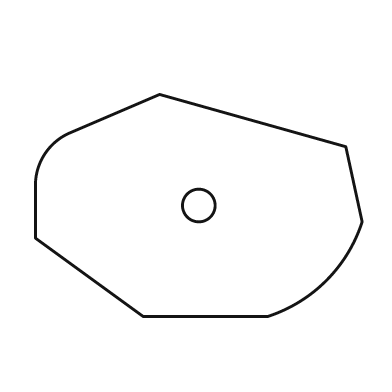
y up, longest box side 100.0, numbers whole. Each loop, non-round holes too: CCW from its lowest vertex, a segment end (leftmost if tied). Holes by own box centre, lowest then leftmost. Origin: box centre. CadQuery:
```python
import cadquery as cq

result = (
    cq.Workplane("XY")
    .moveTo(-17.0, -34.0)
    .lineTo(21.0, -34.0)
    .threePointArc((39.0, -23.0), (50.0, -5.0))
    .lineTo(45.0, 18.0)
    .lineTo(-12.0, 34.0)
    .lineTo(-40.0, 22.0)
    .threePointArc((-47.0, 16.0), (-50.0, 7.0))
    .lineTo(-50.0, -10.0)
    .close()
    .moveTo(0.0, 0.0)
    .circle(5.0)
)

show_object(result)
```